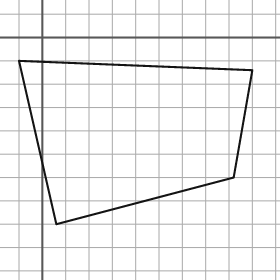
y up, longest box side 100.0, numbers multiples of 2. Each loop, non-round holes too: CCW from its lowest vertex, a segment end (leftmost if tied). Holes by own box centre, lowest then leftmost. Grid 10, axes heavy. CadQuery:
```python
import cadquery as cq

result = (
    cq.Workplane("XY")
    .moveTo(6.0, -80.0)
    .lineTo(82.0, -60.0)
    .lineTo(90.0, -14.0)
    .lineTo(-10.0, -10.0)
    .close()
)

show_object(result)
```